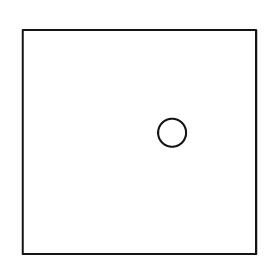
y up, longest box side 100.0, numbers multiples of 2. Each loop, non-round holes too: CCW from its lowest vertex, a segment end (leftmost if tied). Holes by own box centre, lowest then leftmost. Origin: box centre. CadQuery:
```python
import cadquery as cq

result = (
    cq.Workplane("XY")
    .moveTo(-50.0, -48.0)
    .lineTo(50.0, -48.0)
    .lineTo(50.0, 48.0)
    .lineTo(-50.0, 48.0)
    .close()
    .moveTo(14.0, 4.0)
    .circle(6.0)
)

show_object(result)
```